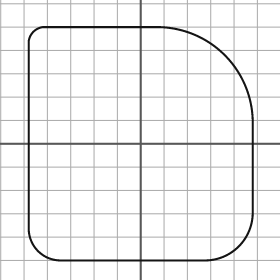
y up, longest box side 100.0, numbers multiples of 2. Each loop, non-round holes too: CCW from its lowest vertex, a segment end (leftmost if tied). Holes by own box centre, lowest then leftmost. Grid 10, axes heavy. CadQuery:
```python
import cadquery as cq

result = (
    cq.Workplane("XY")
    .moveTo(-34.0, -50.0)
    .lineTo(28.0, -50.0)
    .threePointArc((42.0, -44.0), (48.0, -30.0))
    .lineTo(48.0, 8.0)
    .threePointArc((36.0, 38.0), (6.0, 50.0))
    .lineTo(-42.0, 50.0)
    .threePointArc((-46.0, 48.0), (-48.0, 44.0))
    .lineTo(-48.0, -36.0)
    .threePointArc((-44.0, -46.0), (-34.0, -50.0))
    .close()
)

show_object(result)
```